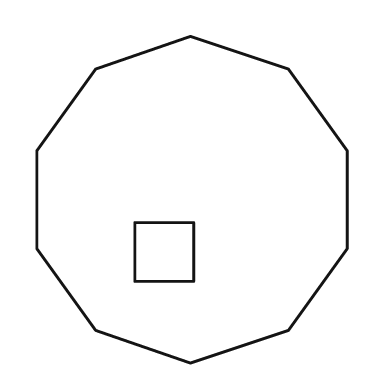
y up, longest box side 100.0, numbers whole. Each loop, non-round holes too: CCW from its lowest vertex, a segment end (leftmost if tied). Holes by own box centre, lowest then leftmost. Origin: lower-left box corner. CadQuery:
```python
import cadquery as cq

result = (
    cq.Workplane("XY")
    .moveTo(47.0, 0.0)
    .lineTo(77.0, 10.0)
    .lineTo(95.0, 35.0)
    .lineTo(95.0, 65.0)
    .lineTo(77.0, 90.0)
    .lineTo(47.0, 100.0)
    .lineTo(18.0, 90.0)
    .lineTo(0.0, 65.0)
    .lineTo(0.0, 35.0)
    .lineTo(18.0, 10.0)
    .close()
    .moveTo(30.0, 25.0)
    .lineTo(48.0, 25.0)
    .lineTo(48.0, 43.0)
    .lineTo(30.0, 43.0)
    .close()
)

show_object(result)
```